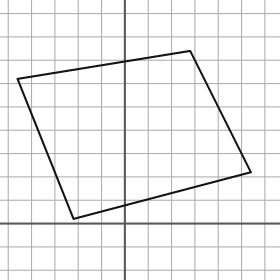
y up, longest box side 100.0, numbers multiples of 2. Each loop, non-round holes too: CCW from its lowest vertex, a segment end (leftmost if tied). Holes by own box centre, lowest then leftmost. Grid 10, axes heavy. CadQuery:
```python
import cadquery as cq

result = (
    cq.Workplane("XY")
    .moveTo(-22.0, 2.0)
    .lineTo(54.0, 22.0)
    .lineTo(28.0, 74.0)
    .lineTo(-46.0, 62.0)
    .close()
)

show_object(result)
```